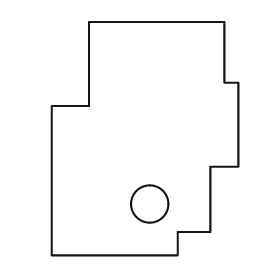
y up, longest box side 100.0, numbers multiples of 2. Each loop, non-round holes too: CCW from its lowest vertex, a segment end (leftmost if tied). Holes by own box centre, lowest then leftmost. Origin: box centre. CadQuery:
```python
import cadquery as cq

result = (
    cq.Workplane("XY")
    .moveTo(-40.0, -50.0)
    .lineTo(14.0, -50.0)
    .lineTo(14.0, -40.0)
    .lineTo(28.0, -40.0)
    .lineTo(28.0, -12.0)
    .lineTo(40.0, -12.0)
    .lineTo(40.0, 24.0)
    .lineTo(34.0, 24.0)
    .lineTo(34.0, 50.0)
    .lineTo(-24.0, 50.0)
    .lineTo(-24.0, 14.0)
    .lineTo(-40.0, 14.0)
    .close()
    .moveTo(2.0, -28.0)
    .circle(8.0)
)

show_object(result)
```